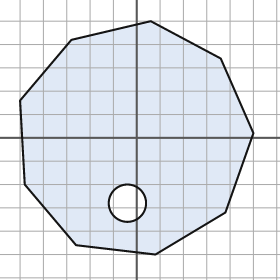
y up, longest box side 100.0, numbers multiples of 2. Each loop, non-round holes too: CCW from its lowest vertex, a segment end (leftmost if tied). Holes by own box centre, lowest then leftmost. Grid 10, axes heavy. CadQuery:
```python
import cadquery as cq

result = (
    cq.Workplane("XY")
    .moveTo(8.0, -50.0)
    .lineTo(38.0, -32.0)
    .lineTo(50.0, 2.0)
    .lineTo(36.0, 34.0)
    .lineTo(6.0, 50.0)
    .lineTo(-28.0, 42.0)
    .lineTo(-50.0, 16.0)
    .lineTo(-48.0, -20.0)
    .lineTo(-26.0, -46.0)
    .close()
    .moveTo(-4.0, -28.0)
    .circle(8.0)
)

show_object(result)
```